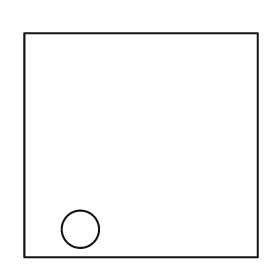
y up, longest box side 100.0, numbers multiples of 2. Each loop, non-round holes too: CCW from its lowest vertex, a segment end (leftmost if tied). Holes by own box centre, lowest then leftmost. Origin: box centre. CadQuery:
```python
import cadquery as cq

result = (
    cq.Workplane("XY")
    .moveTo(-50.0, -48.0)
    .lineTo(50.0, -48.0)
    .lineTo(50.0, 48.0)
    .lineTo(-50.0, 48.0)
    .close()
    .moveTo(-26.0, -36.0)
    .circle(8.0)
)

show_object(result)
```